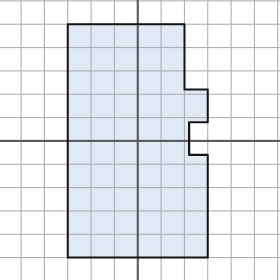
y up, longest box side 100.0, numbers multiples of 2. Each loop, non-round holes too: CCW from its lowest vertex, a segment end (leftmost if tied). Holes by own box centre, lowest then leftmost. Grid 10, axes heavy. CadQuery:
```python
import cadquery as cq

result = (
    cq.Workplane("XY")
    .moveTo(-30.0, -50.0)
    .lineTo(30.0, -50.0)
    .lineTo(30.0, -6.0)
    .lineTo(22.0, -6.0)
    .lineTo(22.0, 8.0)
    .lineTo(30.0, 8.0)
    .lineTo(30.0, 22.0)
    .lineTo(20.0, 22.0)
    .lineTo(20.0, 50.0)
    .lineTo(-30.0, 50.0)
    .close()
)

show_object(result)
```